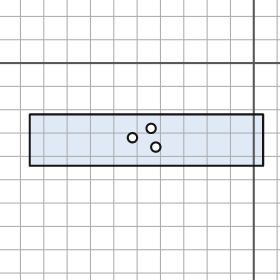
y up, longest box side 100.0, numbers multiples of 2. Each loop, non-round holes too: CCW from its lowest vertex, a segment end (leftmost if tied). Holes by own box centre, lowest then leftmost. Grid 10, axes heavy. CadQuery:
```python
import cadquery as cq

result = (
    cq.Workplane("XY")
    .moveTo(-96.0, -44.0)
    .lineTo(4.0, -44.0)
    .lineTo(4.0, -22.0)
    .lineTo(-96.0, -22.0)
    .close()
    .moveTo(-42.0, -36.0)
    .circle(2.0)
    .moveTo(-52.0, -32.0)
    .circle(2.0)
    .moveTo(-44.0, -28.0)
    .circle(2.0)
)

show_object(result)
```